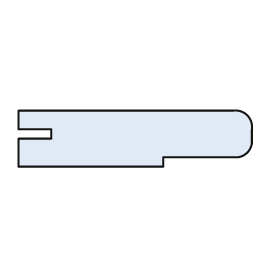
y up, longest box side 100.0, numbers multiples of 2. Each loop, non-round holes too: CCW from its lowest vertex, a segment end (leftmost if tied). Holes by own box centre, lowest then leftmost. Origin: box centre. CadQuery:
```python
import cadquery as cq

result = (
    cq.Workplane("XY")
    .moveTo(-50.0, -12.0)
    .lineTo(12.0, -12.0)
    .lineTo(12.0, -8.0)
    .lineTo(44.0, -8.0)
    .threePointArc((48.0, -6.0), (50.0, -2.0))
    .lineTo(50.0, 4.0)
    .threePointArc((48.0, 10.0), (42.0, 12.0))
    .lineTo(-50.0, 12.0)
    .lineTo(-50.0, 4.0)
    .lineTo(-36.0, 4.0)
    .lineTo(-36.0, 0.0)
    .lineTo(-50.0, 0.0)
    .close()
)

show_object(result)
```